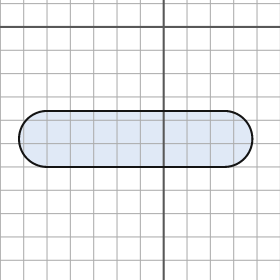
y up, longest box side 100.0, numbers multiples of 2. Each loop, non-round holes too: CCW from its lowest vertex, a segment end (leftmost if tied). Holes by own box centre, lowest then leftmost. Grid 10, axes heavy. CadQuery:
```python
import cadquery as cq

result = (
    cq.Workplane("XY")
    .moveTo(-50.0, -60.0)
    .lineTo(26.0, -60.0)
    .threePointArc((38.0, -48.0), (26.0, -36.0))
    .lineTo(-50.0, -36.0)
    .threePointArc((-62.0, -48.0), (-50.0, -60.0))
    .close()
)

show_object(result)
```